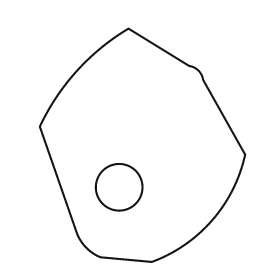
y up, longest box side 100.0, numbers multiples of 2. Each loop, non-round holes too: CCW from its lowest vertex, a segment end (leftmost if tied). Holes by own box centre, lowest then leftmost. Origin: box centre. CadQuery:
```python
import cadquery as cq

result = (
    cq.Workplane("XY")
    .moveTo(4.0, -50.0)
    .threePointArc((30.0, -32.0), (44.0, -4.0))
    .lineTo(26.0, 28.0)
    .threePointArc((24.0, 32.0), (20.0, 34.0))
    .lineTo(-6.0, 50.0)
    .threePointArc((-28.0, 32.0), (-44.0, 8.0))
    .lineTo(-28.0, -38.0)
    .threePointArc((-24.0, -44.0), (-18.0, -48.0))
    .close()
    .moveTo(-10.0, -18.0)
    .circle(10.0)
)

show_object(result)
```